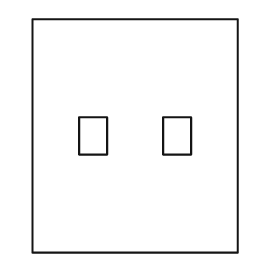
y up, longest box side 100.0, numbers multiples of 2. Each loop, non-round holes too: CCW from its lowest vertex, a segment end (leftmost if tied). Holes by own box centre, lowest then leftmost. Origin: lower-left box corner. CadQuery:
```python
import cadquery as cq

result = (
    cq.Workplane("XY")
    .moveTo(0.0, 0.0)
    .lineTo(88.0, 0.0)
    .lineTo(88.0, 100.0)
    .lineTo(0.0, 100.0)
    .close()
    .moveTo(20.0, 42.0)
    .lineTo(32.0, 42.0)
    .lineTo(32.0, 58.0)
    .lineTo(20.0, 58.0)
    .close()
    .moveTo(56.0, 42.0)
    .lineTo(68.0, 42.0)
    .lineTo(68.0, 58.0)
    .lineTo(56.0, 58.0)
    .close()
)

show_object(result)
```